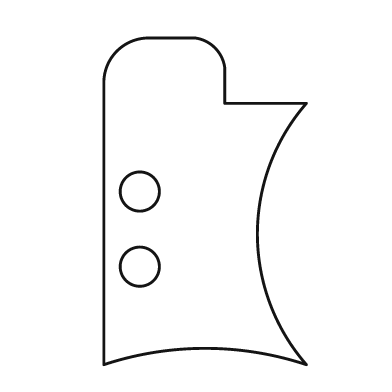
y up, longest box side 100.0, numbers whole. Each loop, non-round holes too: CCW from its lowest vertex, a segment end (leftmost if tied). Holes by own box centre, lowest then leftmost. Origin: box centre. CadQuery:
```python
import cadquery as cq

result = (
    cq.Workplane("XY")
    .moveTo(-31.0, -50.0)
    .threePointArc((0.0, -45.0), (31.0, -50.0))
    .threePointArc((16.0, -10.0), (31.0, 30.0))
    .lineTo(6.0, 30.0)
    .lineTo(6.0, 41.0)
    .threePointArc((3.0, 47.0), (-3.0, 50.0))
    .lineTo(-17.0, 50.0)
    .threePointArc((-27.0, 46.0), (-31.0, 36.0))
    .close()
    .moveTo(-20.0, -20.0)
    .circle(6.0)
    .moveTo(-20.0, 3.0)
    .circle(6.0)
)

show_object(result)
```